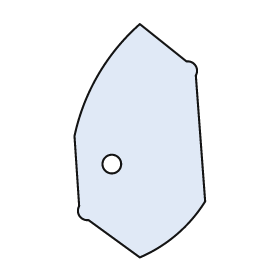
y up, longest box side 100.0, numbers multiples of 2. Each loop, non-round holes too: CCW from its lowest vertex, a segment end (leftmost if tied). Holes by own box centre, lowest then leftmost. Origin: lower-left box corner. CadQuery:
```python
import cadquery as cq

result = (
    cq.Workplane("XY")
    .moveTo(28.0, 0.0)
    .threePointArc((44.0, 10.0), (56.0, 24.0))
    .lineTo(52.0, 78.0)
    .threePointArc((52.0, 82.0), (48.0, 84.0))
    .lineTo(28.0, 100.0)
    .threePointArc((10.0, 78.0), (0.0, 52.0))
    .lineTo(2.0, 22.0)
    .threePointArc((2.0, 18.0), (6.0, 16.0))
    .close()
    .moveTo(16.0, 40.0)
    .circle(4.0)
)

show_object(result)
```